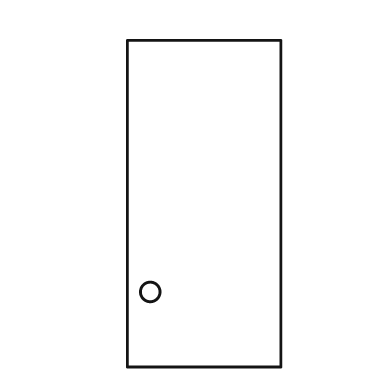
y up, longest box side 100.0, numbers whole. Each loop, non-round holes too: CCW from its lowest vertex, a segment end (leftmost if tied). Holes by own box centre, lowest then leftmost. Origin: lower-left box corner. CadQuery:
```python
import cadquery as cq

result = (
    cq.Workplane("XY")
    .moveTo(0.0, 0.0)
    .lineTo(47.0, 0.0)
    .lineTo(47.0, 100.0)
    .lineTo(0.0, 100.0)
    .close()
    .moveTo(7.0, 23.0)
    .circle(3.0)
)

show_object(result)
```